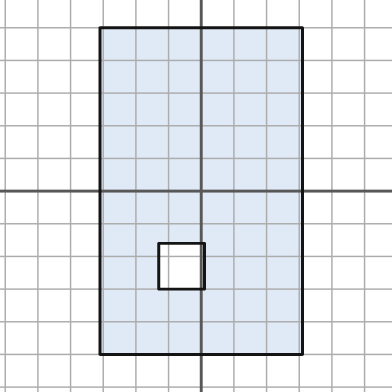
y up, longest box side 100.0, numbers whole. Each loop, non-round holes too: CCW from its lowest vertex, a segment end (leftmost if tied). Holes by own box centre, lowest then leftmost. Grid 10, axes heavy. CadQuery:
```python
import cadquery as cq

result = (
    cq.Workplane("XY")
    .moveTo(-31.0, -50.0)
    .lineTo(31.0, -50.0)
    .lineTo(31.0, 50.0)
    .lineTo(-31.0, 50.0)
    .close()
    .moveTo(-13.0, -30.0)
    .lineTo(1.0, -30.0)
    .lineTo(1.0, -16.0)
    .lineTo(-13.0, -16.0)
    .close()
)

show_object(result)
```